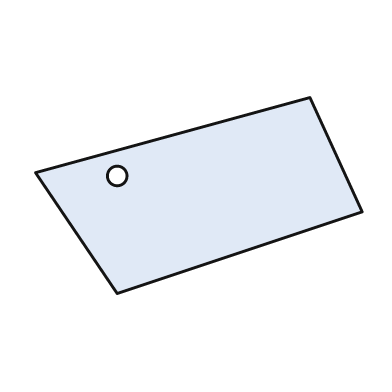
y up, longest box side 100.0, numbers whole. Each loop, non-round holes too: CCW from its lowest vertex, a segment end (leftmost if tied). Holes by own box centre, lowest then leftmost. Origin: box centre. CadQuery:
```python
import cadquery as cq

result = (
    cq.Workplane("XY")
    .moveTo(-25.0, -30.0)
    .lineTo(50.0, -5.0)
    .lineTo(34.0, 30.0)
    .lineTo(-50.0, 7.0)
    .close()
    .moveTo(-25.0, 6.0)
    .circle(3.0)
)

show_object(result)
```